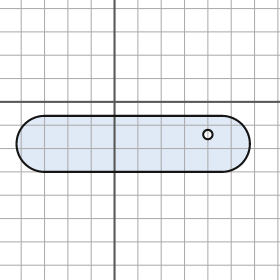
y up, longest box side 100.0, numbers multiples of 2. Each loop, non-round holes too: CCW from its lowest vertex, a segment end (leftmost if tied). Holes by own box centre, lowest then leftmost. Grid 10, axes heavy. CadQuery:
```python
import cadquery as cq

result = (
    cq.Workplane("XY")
    .moveTo(-30.0, -30.0)
    .lineTo(46.0, -30.0)
    .threePointArc((58.0, -18.0), (46.0, -6.0))
    .lineTo(-30.0, -6.0)
    .threePointArc((-42.0, -18.0), (-30.0, -30.0))
    .close()
    .moveTo(40.0, -14.0)
    .circle(2.0)
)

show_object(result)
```